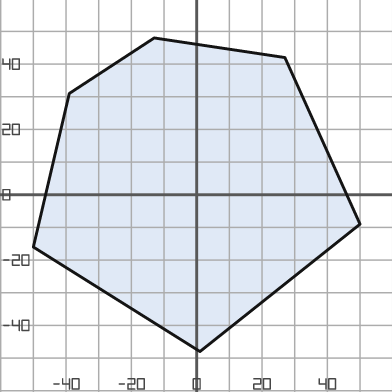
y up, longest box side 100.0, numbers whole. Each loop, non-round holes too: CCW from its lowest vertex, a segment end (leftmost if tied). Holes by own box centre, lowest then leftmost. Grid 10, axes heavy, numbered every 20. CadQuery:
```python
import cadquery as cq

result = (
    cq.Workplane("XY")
    .moveTo(1.0, -48.0)
    .lineTo(50.0, -9.0)
    .lineTo(27.0, 42.0)
    .lineTo(-13.0, 48.0)
    .lineTo(-39.0, 31.0)
    .lineTo(-50.0, -16.0)
    .close()
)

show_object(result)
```